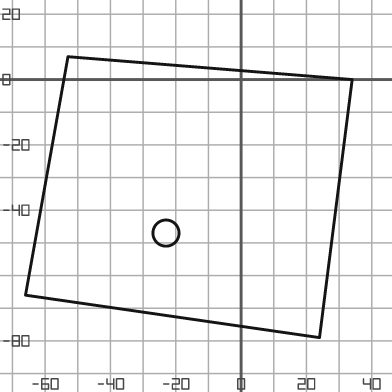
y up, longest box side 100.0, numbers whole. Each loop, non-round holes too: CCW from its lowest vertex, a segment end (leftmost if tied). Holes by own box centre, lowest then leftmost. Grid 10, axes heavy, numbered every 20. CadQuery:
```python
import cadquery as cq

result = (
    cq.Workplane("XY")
    .moveTo(24.0, -79.0)
    .lineTo(34.0, 0.0)
    .lineTo(-53.0, 7.0)
    .lineTo(-66.0, -66.0)
    .close()
    .moveTo(-23.0, -47.0)
    .circle(4.0)
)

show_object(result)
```